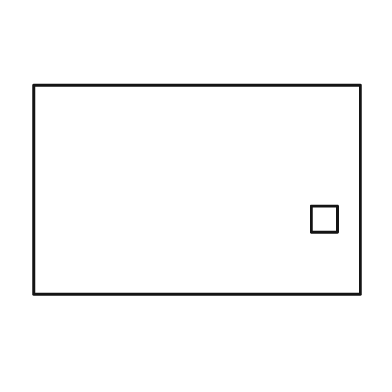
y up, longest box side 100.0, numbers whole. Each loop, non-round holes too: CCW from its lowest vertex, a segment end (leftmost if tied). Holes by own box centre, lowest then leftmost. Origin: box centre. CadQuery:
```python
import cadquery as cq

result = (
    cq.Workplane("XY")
    .moveTo(-50.0, -32.0)
    .lineTo(50.0, -32.0)
    .lineTo(50.0, 32.0)
    .lineTo(-50.0, 32.0)
    .close()
    .moveTo(35.0, -13.0)
    .lineTo(43.0, -13.0)
    .lineTo(43.0, -5.0)
    .lineTo(35.0, -5.0)
    .close()
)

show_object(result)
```